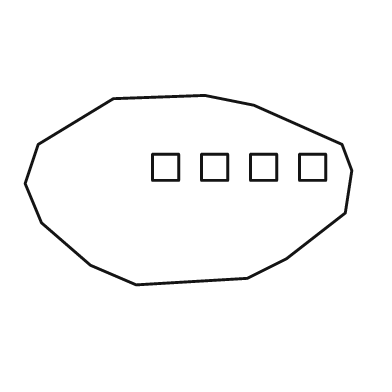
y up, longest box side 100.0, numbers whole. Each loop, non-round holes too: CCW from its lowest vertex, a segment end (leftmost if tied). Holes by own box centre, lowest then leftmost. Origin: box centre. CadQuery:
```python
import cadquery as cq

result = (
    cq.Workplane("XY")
    .moveTo(-16.0, -29.0)
    .lineTo(18.0, -27.0)
    .lineTo(30.0, -21.0)
    .lineTo(48.0, -7.0)
    .lineTo(50.0, 6.0)
    .lineTo(47.0, 14.0)
    .lineTo(20.0, 26.0)
    .lineTo(5.0, 29.0)
    .lineTo(-23.0, 28.0)
    .lineTo(-46.0, 14.0)
    .lineTo(-50.0, 2.0)
    .lineTo(-45.0, -10.0)
    .lineTo(-30.0, -23.0)
    .close()
    .moveTo(-11.0, 3.0)
    .lineTo(-3.0, 3.0)
    .lineTo(-3.0, 11.0)
    .lineTo(-11.0, 11.0)
    .close()
    .moveTo(4.0, 3.0)
    .lineTo(12.0, 3.0)
    .lineTo(12.0, 11.0)
    .lineTo(4.0, 11.0)
    .close()
    .moveTo(19.0, 3.0)
    .lineTo(27.0, 3.0)
    .lineTo(27.0, 11.0)
    .lineTo(19.0, 11.0)
    .close()
    .moveTo(34.0, 3.0)
    .lineTo(42.0, 3.0)
    .lineTo(42.0, 11.0)
    .lineTo(34.0, 11.0)
    .close()
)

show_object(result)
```